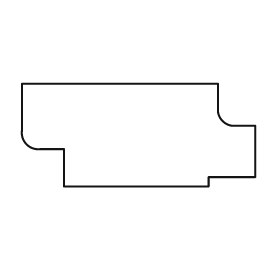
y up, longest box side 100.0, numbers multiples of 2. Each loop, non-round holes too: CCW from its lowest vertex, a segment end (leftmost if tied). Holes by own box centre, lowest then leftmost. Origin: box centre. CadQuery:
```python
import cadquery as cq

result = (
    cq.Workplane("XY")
    .moveTo(-32.0, -22.0)
    .lineTo(30.0, -22.0)
    .lineTo(30.0, -18.0)
    .lineTo(50.0, -18.0)
    .lineTo(50.0, 4.0)
    .lineTo(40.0, 4.0)
    .threePointArc((36.0, 6.0), (34.0, 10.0))
    .lineTo(34.0, 22.0)
    .lineTo(-50.0, 22.0)
    .lineTo(-50.0, 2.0)
    .threePointArc((-48.0, -4.0), (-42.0, -6.0))
    .lineTo(-32.0, -6.0)
    .close()
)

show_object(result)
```